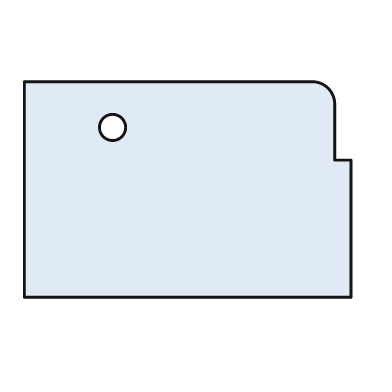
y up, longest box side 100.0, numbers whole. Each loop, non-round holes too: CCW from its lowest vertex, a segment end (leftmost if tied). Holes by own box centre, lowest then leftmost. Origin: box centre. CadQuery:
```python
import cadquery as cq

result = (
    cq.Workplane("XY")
    .moveTo(-50.0, -33.0)
    .lineTo(50.0, -33.0)
    .lineTo(50.0, 9.0)
    .lineTo(45.0, 9.0)
    .lineTo(45.0, 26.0)
    .threePointArc((43.0, 31.0), (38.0, 33.0))
    .lineTo(-50.0, 33.0)
    .close()
    .moveTo(-23.0, 19.0)
    .circle(4.0)
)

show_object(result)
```